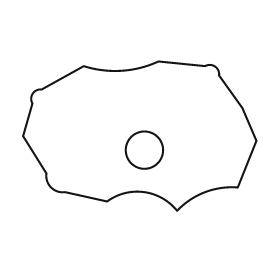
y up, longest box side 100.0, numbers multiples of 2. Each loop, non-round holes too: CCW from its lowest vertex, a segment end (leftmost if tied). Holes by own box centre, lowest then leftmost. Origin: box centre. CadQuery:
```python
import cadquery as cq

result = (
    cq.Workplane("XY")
    .moveTo(16.0, -32.0)
    .threePointArc((28.0, -24.0), (42.0, -22.0))
    .lineTo(50.0, -2.0)
    .lineTo(44.0, 12.0)
    .lineTo(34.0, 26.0)
    .threePointArc((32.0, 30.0), (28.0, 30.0))
    .lineTo(8.0, 32.0)
    .threePointArc((-8.0, 28.0), (-24.0, 30.0))
    .lineTo(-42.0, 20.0)
    .threePointArc((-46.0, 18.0), (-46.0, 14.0))
    .lineTo(-50.0, 0.0)
    .lineTo(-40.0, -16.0)
    .threePointArc((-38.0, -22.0), (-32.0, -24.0))
    .lineTo(-14.0, -28.0)
    .threePointArc((2.0, -24.0), (16.0, -32.0))
    .close()
    .moveTo(2.0, -6.0)
    .circle(8.0)
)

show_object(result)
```